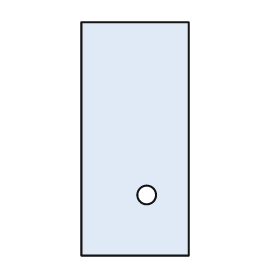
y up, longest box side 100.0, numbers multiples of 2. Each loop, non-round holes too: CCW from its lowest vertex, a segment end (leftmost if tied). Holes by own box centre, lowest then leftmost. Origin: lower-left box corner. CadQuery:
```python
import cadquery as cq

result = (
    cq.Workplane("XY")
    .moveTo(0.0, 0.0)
    .lineTo(46.0, 0.0)
    .lineTo(46.0, 100.0)
    .lineTo(0.0, 100.0)
    .close()
    .moveTo(28.0, 26.0)
    .circle(4.0)
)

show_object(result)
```